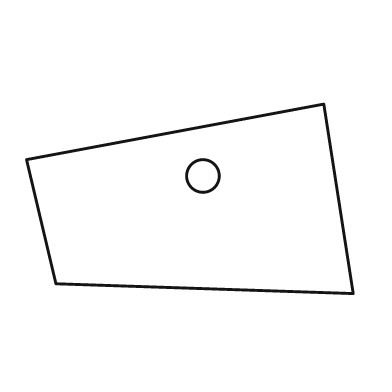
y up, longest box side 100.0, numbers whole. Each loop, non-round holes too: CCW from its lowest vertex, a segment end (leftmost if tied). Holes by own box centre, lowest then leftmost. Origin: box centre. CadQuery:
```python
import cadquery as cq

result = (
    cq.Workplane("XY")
    .moveTo(50.0, -29.0)
    .lineTo(41.0, 29.0)
    .lineTo(-50.0, 12.0)
    .lineTo(-41.0, -26.0)
    .close()
    .moveTo(4.0, 7.0)
    .circle(5.0)
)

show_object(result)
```